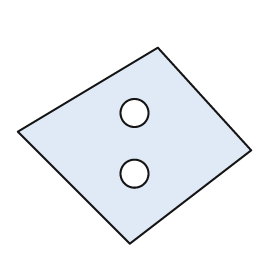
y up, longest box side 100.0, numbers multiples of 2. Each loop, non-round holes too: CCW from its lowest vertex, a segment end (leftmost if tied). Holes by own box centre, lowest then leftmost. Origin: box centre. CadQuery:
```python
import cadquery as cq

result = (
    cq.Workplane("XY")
    .moveTo(-2.0, -42.0)
    .lineTo(50.0, -2.0)
    .lineTo(10.0, 42.0)
    .lineTo(-50.0, 6.0)
    .close()
    .moveTo(0.0, -12.0)
    .circle(6.0)
    .moveTo(0.0, 14.0)
    .circle(6.0)
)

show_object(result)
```